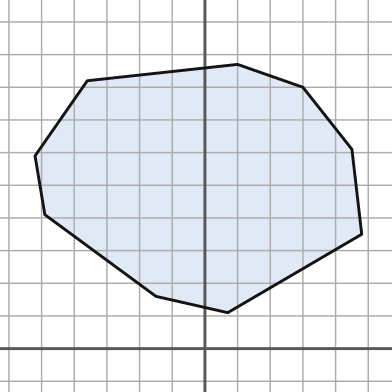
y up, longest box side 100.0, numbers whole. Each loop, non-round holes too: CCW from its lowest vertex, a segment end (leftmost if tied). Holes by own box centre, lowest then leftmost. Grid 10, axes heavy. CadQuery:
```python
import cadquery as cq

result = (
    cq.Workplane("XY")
    .moveTo(7.0, 11.0)
    .lineTo(48.0, 35.0)
    .lineTo(45.0, 61.0)
    .lineTo(30.0, 80.0)
    .lineTo(10.0, 87.0)
    .lineTo(-36.0, 82.0)
    .lineTo(-52.0, 59.0)
    .lineTo(-49.0, 41.0)
    .lineTo(-15.0, 16.0)
    .close()
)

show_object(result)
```